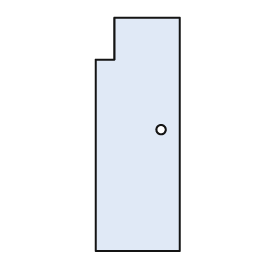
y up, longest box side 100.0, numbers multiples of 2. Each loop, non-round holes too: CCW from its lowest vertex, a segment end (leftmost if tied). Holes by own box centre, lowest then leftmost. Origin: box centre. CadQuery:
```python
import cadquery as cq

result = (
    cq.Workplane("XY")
    .moveTo(-18.0, -50.0)
    .lineTo(18.0, -50.0)
    .lineTo(18.0, 50.0)
    .lineTo(-10.0, 50.0)
    .lineTo(-10.0, 32.0)
    .lineTo(-18.0, 32.0)
    .close()
    .moveTo(10.0, 2.0)
    .circle(2.0)
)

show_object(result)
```